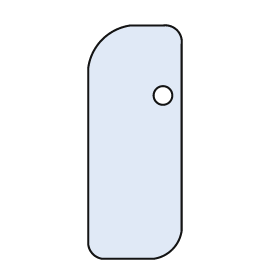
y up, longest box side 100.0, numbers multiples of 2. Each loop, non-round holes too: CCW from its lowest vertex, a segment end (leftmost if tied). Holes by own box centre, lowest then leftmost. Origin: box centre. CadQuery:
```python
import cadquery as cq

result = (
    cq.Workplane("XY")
    .moveTo(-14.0, -50.0)
    .lineTo(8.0, -50.0)
    .threePointArc((16.0, -46.0), (20.0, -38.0))
    .lineTo(20.0, 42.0)
    .threePointArc((18.0, 48.0), (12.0, 50.0))
    .lineTo(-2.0, 50.0)
    .threePointArc((-14.0, 44.0), (-20.0, 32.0))
    .lineTo(-20.0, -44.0)
    .threePointArc((-18.0, -48.0), (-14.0, -50.0))
    .close()
    .moveTo(12.0, 20.0)
    .circle(4.0)
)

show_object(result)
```